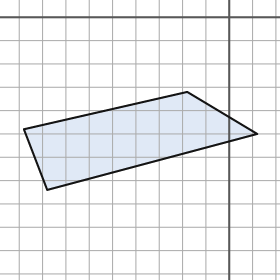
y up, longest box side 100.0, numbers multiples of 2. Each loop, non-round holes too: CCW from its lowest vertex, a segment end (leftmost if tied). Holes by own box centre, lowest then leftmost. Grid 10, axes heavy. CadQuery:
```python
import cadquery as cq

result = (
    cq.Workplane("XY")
    .moveTo(-78.0, -74.0)
    .lineTo(12.0, -50.0)
    .lineTo(-18.0, -32.0)
    .lineTo(-88.0, -48.0)
    .close()
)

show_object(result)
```